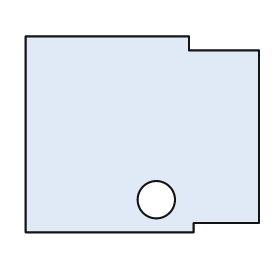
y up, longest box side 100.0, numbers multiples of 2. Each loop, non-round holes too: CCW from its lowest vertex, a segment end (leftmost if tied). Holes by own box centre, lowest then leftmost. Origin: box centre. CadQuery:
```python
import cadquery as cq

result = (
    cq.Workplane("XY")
    .moveTo(-50.0, -42.0)
    .lineTo(22.0, -42.0)
    .lineTo(22.0, -38.0)
    .lineTo(50.0, -38.0)
    .lineTo(50.0, 36.0)
    .lineTo(20.0, 36.0)
    .lineTo(20.0, 42.0)
    .lineTo(-50.0, 42.0)
    .close()
    .moveTo(6.0, -28.0)
    .circle(8.0)
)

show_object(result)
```